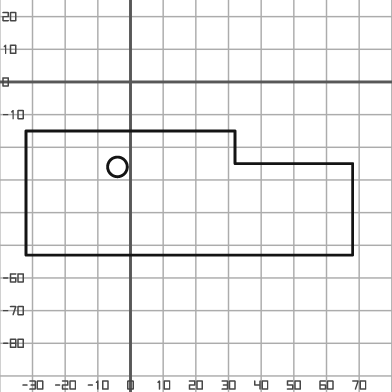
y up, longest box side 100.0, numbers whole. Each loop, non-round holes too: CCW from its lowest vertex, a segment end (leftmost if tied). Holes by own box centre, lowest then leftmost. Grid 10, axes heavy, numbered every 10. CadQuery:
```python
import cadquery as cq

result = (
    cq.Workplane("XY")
    .moveTo(-32.0, -53.0)
    .lineTo(68.0, -53.0)
    .lineTo(68.0, -25.0)
    .lineTo(32.0, -25.0)
    .lineTo(32.0, -15.0)
    .lineTo(-32.0, -15.0)
    .close()
    .moveTo(-4.0, -26.0)
    .circle(3.0)
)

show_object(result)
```